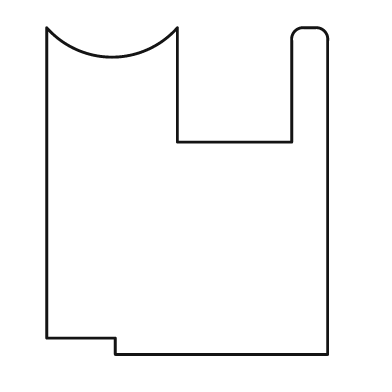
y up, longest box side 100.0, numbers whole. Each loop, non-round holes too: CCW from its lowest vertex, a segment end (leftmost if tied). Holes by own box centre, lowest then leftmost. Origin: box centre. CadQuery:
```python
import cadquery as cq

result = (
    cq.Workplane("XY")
    .moveTo(-22.0, -50.0)
    .lineTo(43.0, -50.0)
    .lineTo(43.0, 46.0)
    .threePointArc((42.0, 49.0), (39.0, 50.0))
    .lineTo(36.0, 50.0)
    .threePointArc((33.0, 49.0), (32.0, 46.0))
    .lineTo(32.0, 15.0)
    .lineTo(-3.0, 15.0)
    .lineTo(-3.0, 50.0)
    .threePointArc((-23.0, 41.0), (-43.0, 50.0))
    .lineTo(-43.0, -45.0)
    .lineTo(-22.0, -45.0)
    .close()
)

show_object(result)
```